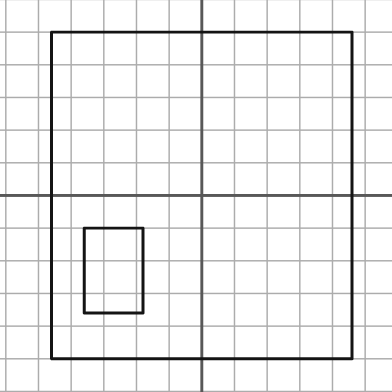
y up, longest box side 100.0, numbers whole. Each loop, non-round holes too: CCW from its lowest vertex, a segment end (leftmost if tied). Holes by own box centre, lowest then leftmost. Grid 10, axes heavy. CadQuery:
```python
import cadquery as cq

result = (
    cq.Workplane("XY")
    .moveTo(-46.0, -50.0)
    .lineTo(46.0, -50.0)
    .lineTo(46.0, 50.0)
    .lineTo(-46.0, 50.0)
    .close()
    .moveTo(-36.0, -36.0)
    .lineTo(-18.0, -36.0)
    .lineTo(-18.0, -10.0)
    .lineTo(-36.0, -10.0)
    .close()
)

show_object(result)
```